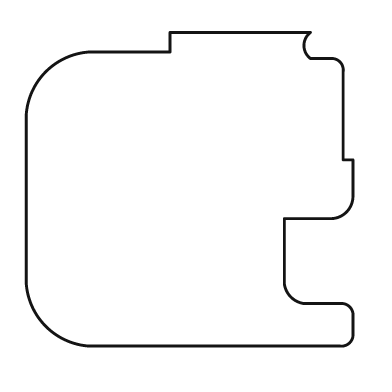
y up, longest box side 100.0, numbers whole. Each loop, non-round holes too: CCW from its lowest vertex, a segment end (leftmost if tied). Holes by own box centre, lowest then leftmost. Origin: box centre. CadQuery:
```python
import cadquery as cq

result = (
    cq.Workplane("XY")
    .moveTo(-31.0, -48.0)
    .lineTo(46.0, -48.0)
    .threePointArc((49.0, -47.0), (50.0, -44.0))
    .lineTo(50.0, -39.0)
    .threePointArc((49.0, -36.0), (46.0, -35.0))
    .lineTo(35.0, -35.0)
    .threePointArc((31.0, -33.0), (29.0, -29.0))
    .lineTo(29.0, -9.0)
    .lineTo(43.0, -9.0)
    .threePointArc((48.0, -7.0), (50.0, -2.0))
    .lineTo(50.0, 9.0)
    .lineTo(47.0, 9.0)
    .lineTo(47.0, 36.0)
    .threePointArc((46.0, 39.0), (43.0, 40.0))
    .lineTo(37.0, 40.0)
    .threePointArc((35.0, 44.0), (37.0, 48.0))
    .lineTo(-6.0, 48.0)
    .lineTo(-6.0, 42.0)
    .lineTo(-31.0, 42.0)
    .threePointArc((-44.0, 36.0), (-50.0, 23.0))
    .lineTo(-50.0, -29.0)
    .threePointArc((-44.0, -42.0), (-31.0, -48.0))
    .close()
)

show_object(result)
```